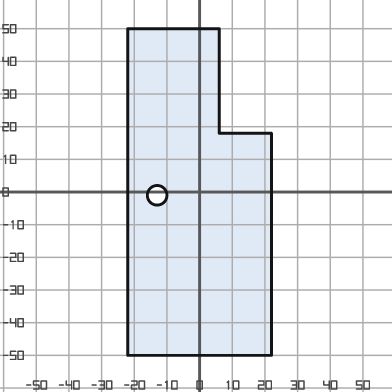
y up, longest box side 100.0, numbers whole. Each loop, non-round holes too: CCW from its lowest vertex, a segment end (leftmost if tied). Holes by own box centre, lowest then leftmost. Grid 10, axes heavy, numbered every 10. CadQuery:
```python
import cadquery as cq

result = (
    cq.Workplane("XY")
    .moveTo(-22.0, -50.0)
    .lineTo(22.0, -50.0)
    .lineTo(22.0, 18.0)
    .lineTo(6.0, 18.0)
    .lineTo(6.0, 50.0)
    .lineTo(-22.0, 50.0)
    .close()
    .moveTo(-13.0, -1.0)
    .circle(3.0)
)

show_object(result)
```